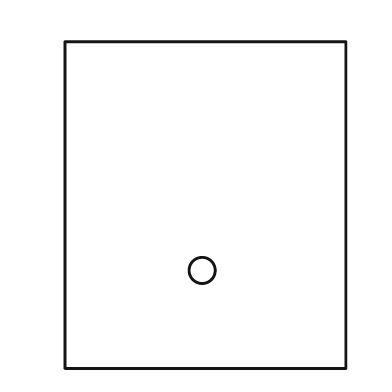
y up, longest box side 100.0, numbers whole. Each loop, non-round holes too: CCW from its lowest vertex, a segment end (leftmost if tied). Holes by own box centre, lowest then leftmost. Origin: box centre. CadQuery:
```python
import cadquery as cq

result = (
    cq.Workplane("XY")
    .moveTo(-43.0, -50.0)
    .lineTo(43.0, -50.0)
    .lineTo(43.0, 50.0)
    .lineTo(-43.0, 50.0)
    .close()
    .moveTo(-1.0, -20.0)
    .circle(4.0)
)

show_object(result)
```